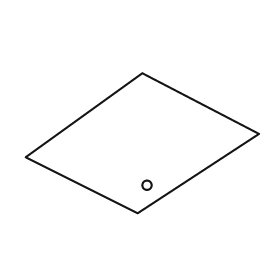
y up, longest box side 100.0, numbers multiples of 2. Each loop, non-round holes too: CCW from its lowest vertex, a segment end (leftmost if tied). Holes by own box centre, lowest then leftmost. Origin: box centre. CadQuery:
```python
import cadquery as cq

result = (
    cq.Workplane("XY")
    .moveTo(-2.0, -30.0)
    .lineTo(50.0, 4.0)
    .lineTo(0.0, 30.0)
    .lineTo(-50.0, -6.0)
    .close()
    .moveTo(2.0, -18.0)
    .circle(2.0)
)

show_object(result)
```